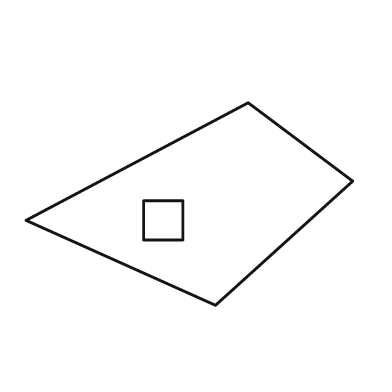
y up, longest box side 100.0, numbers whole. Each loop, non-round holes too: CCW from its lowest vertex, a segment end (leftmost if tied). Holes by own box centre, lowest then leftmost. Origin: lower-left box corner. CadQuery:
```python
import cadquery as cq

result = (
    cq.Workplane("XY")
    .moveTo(58.0, 0.0)
    .lineTo(100.0, 38.0)
    .lineTo(68.0, 62.0)
    .lineTo(0.0, 26.0)
    .close()
    .moveTo(36.0, 20.0)
    .lineTo(48.0, 20.0)
    .lineTo(48.0, 32.0)
    .lineTo(36.0, 32.0)
    .close()
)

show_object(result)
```